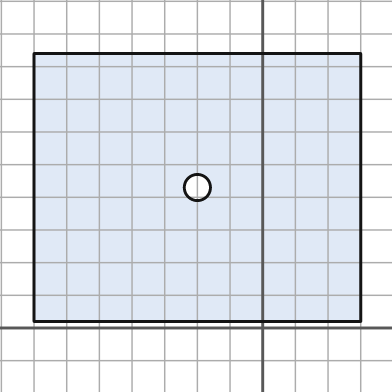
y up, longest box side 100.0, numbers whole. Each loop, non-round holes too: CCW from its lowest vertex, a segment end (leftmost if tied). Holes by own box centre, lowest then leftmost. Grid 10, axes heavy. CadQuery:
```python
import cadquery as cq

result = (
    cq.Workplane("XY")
    .moveTo(-70.0, 2.0)
    .lineTo(30.0, 2.0)
    .lineTo(30.0, 84.0)
    .lineTo(-70.0, 84.0)
    .close()
    .moveTo(-20.0, 43.0)
    .circle(4.0)
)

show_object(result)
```